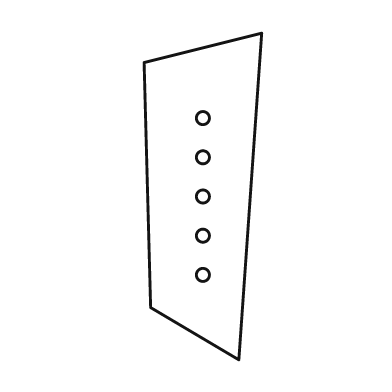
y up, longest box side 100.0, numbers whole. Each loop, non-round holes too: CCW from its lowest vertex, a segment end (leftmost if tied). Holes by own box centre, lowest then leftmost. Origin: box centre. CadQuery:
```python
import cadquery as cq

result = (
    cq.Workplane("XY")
    .moveTo(11.0, -50.0)
    .lineTo(18.0, 50.0)
    .lineTo(-18.0, 41.0)
    .lineTo(-16.0, -34.0)
    .close()
    .moveTo(0.0, -24.0)
    .circle(2.0)
    .moveTo(0.0, -12.0)
    .circle(2.0)
    .moveTo(0.0, 0.0)
    .circle(2.0)
    .moveTo(0.0, 12.0)
    .circle(2.0)
    .moveTo(0.0, 24.0)
    .circle(2.0)
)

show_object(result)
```